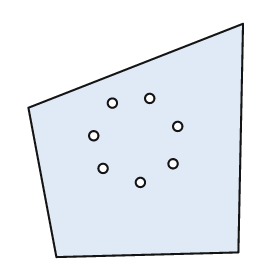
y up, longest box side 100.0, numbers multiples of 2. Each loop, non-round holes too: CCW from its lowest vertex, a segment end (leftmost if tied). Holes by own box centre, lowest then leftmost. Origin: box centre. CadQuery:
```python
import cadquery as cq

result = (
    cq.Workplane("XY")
    .moveTo(-34.0, -50.0)
    .lineTo(44.0, -48.0)
    .lineTo(46.0, 50.0)
    .lineTo(-46.0, 14.0)
    .close()
    .moveTo(2.0, -18.0)
    .circle(2.0)
    .moveTo(-14.0, -12.0)
    .circle(2.0)
    .moveTo(16.0, -10.0)
    .circle(2.0)
    .moveTo(-18.0, 2.0)
    .circle(2.0)
    .moveTo(18.0, 6.0)
    .circle(2.0)
    .moveTo(-10.0, 16.0)
    .circle(2.0)
    .moveTo(6.0, 18.0)
    .circle(2.0)
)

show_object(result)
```